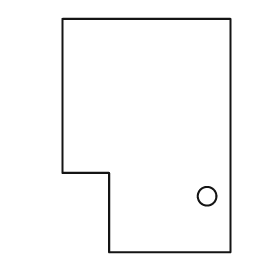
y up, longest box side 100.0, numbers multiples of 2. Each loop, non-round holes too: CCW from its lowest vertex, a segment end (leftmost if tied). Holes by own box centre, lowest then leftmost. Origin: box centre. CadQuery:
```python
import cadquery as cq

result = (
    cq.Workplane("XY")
    .moveTo(-16.0, -50.0)
    .lineTo(36.0, -50.0)
    .lineTo(36.0, 50.0)
    .lineTo(-36.0, 50.0)
    .lineTo(-36.0, -16.0)
    .lineTo(-16.0, -16.0)
    .close()
    .moveTo(26.0, -26.0)
    .circle(4.0)
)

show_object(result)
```